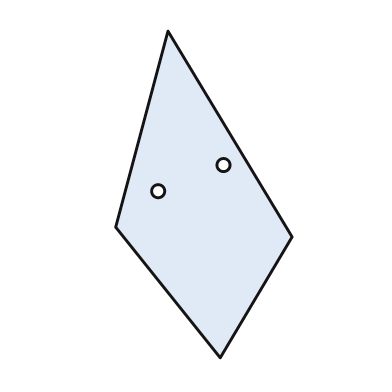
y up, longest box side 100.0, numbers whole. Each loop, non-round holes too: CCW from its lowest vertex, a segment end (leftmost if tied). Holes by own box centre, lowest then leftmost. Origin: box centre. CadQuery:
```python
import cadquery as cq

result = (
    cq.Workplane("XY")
    .moveTo(5.0, -50.0)
    .lineTo(27.0, -13.0)
    .lineTo(-11.0, 50.0)
    .lineTo(-27.0, -10.0)
    .close()
    .moveTo(-14.0, 1.0)
    .circle(2.0)
    .moveTo(6.0, 9.0)
    .circle(2.0)
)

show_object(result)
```